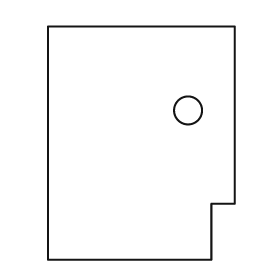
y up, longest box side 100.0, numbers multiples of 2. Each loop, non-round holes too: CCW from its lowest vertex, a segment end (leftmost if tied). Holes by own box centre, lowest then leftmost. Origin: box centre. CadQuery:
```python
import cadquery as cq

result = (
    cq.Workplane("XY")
    .moveTo(-40.0, -50.0)
    .lineTo(30.0, -50.0)
    .lineTo(30.0, -26.0)
    .lineTo(40.0, -26.0)
    .lineTo(40.0, 50.0)
    .lineTo(-40.0, 50.0)
    .close()
    .moveTo(20.0, 14.0)
    .circle(6.0)
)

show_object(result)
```